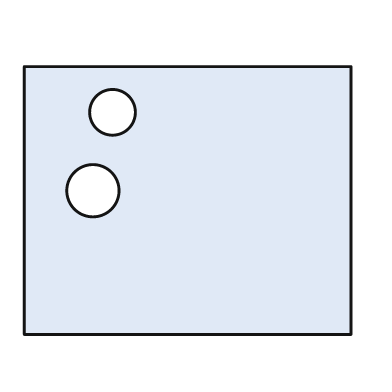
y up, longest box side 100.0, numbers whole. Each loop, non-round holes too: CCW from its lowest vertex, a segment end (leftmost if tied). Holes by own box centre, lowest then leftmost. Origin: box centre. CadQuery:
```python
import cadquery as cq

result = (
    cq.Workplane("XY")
    .moveTo(-50.0, -41.0)
    .lineTo(50.0, -41.0)
    .lineTo(50.0, 41.0)
    .lineTo(-50.0, 41.0)
    .close()
    .moveTo(-29.0, 3.0)
    .circle(8.0)
    .moveTo(-23.0, 27.0)
    .circle(7.0)
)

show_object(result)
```